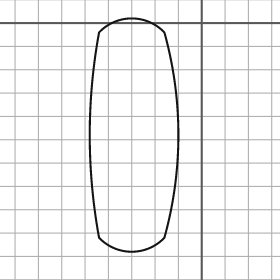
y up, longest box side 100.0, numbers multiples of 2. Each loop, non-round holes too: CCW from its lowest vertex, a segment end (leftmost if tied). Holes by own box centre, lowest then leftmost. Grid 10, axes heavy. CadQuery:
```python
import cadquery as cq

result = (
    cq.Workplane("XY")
    .moveTo(-44.0, -92.0)
    .threePointArc((-30.0, -98.0), (-16.0, -92.0))
    .threePointArc((-10.0, -48.0), (-16.0, -4.0))
    .threePointArc((-30.0, 2.0), (-44.0, -4.0))
    .threePointArc((-48.0, -48.0), (-44.0, -92.0))
    .close()
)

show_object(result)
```